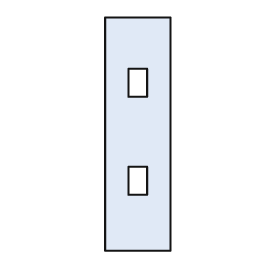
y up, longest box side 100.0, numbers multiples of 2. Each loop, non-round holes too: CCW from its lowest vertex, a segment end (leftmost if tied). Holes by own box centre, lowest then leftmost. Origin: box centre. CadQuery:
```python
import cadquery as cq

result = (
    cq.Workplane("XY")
    .moveTo(-14.0, -50.0)
    .lineTo(14.0, -50.0)
    .lineTo(14.0, 50.0)
    .lineTo(-14.0, 50.0)
    .close()
    .moveTo(-4.0, -26.0)
    .lineTo(4.0, -26.0)
    .lineTo(4.0, -14.0)
    .lineTo(-4.0, -14.0)
    .close()
    .moveTo(-4.0, 16.0)
    .lineTo(4.0, 16.0)
    .lineTo(4.0, 28.0)
    .lineTo(-4.0, 28.0)
    .close()
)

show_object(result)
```